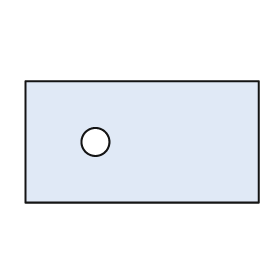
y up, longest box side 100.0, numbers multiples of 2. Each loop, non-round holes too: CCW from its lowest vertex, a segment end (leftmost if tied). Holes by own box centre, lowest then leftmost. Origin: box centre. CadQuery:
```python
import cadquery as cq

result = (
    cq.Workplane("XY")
    .moveTo(-50.0, -26.0)
    .lineTo(50.0, -26.0)
    .lineTo(50.0, 26.0)
    .lineTo(-50.0, 26.0)
    .close()
    .moveTo(-20.0, 0.0)
    .circle(6.0)
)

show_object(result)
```